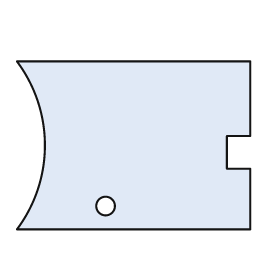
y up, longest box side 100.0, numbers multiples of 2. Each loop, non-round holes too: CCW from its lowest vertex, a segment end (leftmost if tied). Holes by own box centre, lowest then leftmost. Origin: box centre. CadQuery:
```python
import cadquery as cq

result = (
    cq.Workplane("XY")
    .moveTo(-50.0, -36.0)
    .lineTo(50.0, -36.0)
    .lineTo(50.0, -10.0)
    .lineTo(40.0, -10.0)
    .lineTo(40.0, 4.0)
    .lineTo(50.0, 4.0)
    .lineTo(50.0, 36.0)
    .lineTo(-50.0, 36.0)
    .threePointArc((-38.0, 0.0), (-50.0, -36.0))
    .close()
    .moveTo(-12.0, -26.0)
    .circle(4.0)
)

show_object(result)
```